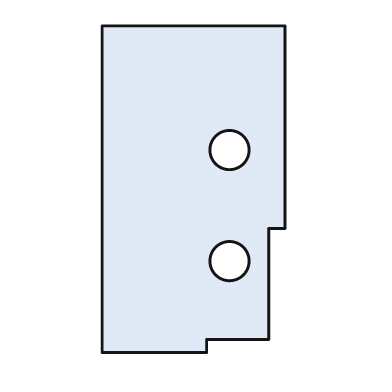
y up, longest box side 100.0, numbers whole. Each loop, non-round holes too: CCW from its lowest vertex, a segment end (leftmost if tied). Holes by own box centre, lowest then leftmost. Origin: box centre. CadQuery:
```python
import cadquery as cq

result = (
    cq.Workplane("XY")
    .moveTo(-28.0, -50.0)
    .lineTo(4.0, -50.0)
    .lineTo(4.0, -46.0)
    .lineTo(23.0, -46.0)
    .lineTo(23.0, -12.0)
    .lineTo(28.0, -12.0)
    .lineTo(28.0, 50.0)
    .lineTo(-28.0, 50.0)
    .close()
    .moveTo(11.0, -22.0)
    .circle(6.0)
    .moveTo(11.0, 12.0)
    .circle(6.0)
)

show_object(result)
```